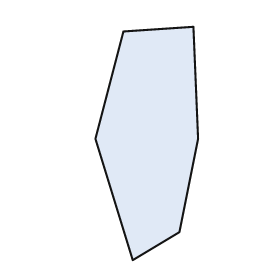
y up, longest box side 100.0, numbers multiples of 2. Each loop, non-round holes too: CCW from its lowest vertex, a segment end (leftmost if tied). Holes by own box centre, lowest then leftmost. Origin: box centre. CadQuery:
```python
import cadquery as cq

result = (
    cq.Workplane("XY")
    .moveTo(-6.0, -50.0)
    .lineTo(14.0, -38.0)
    .lineTo(22.0, 2.0)
    .lineTo(20.0, 50.0)
    .lineTo(-10.0, 48.0)
    .lineTo(-22.0, 2.0)
    .close()
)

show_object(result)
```